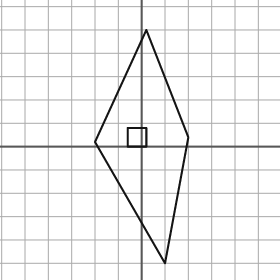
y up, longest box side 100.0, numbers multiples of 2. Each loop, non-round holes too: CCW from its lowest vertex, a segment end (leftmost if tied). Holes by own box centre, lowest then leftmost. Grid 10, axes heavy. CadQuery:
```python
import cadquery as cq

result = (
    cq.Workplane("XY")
    .moveTo(10.0, -50.0)
    .lineTo(20.0, 4.0)
    .lineTo(2.0, 50.0)
    .lineTo(-20.0, 2.0)
    .close()
    .moveTo(-6.0, 0.0)
    .lineTo(2.0, 0.0)
    .lineTo(2.0, 8.0)
    .lineTo(-6.0, 8.0)
    .close()
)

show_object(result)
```